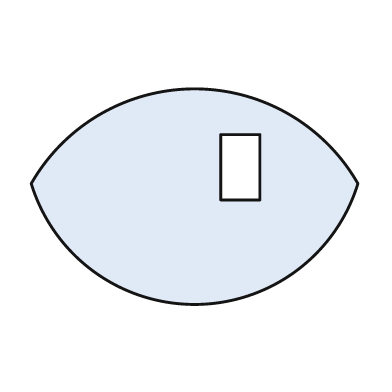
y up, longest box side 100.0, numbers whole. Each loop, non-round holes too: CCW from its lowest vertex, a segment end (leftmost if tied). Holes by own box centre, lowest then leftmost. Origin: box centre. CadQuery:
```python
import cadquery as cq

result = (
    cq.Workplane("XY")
    .moveTo(-50.0, 4.0)
    .threePointArc((0.0, -33.0), (50.0, 4.0))
    .threePointArc((0.0, 33.0), (-50.0, 4.0))
    .close()
    .moveTo(8.0, -1.0)
    .lineTo(20.0, -1.0)
    .lineTo(20.0, 19.0)
    .lineTo(8.0, 19.0)
    .close()
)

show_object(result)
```